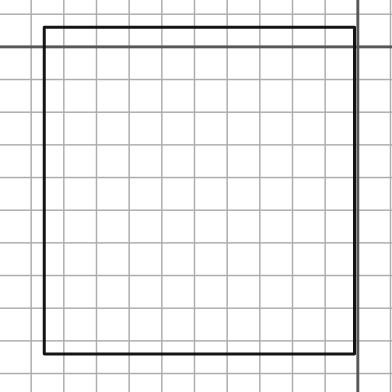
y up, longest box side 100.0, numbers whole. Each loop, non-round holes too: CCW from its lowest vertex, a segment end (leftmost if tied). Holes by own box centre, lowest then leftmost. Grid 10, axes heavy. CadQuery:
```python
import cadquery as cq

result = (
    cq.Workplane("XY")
    .moveTo(-96.0, -94.0)
    .lineTo(-1.0, -94.0)
    .lineTo(-1.0, 6.0)
    .lineTo(-96.0, 6.0)
    .close()
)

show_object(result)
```